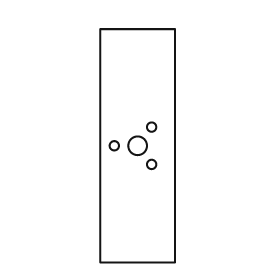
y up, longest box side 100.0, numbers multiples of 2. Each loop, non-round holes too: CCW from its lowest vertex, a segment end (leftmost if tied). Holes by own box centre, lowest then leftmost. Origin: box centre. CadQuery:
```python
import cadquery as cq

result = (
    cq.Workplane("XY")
    .moveTo(-16.0, -50.0)
    .lineTo(16.0, -50.0)
    .lineTo(16.0, 50.0)
    .lineTo(-16.0, 50.0)
    .close()
    .moveTo(6.0, -8.0)
    .circle(2.0)
    .moveTo(-10.0, 0.0)
    .circle(2.0)
    .moveTo(0.0, 0.0)
    .circle(4.0)
    .moveTo(6.0, 8.0)
    .circle(2.0)
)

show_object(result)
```